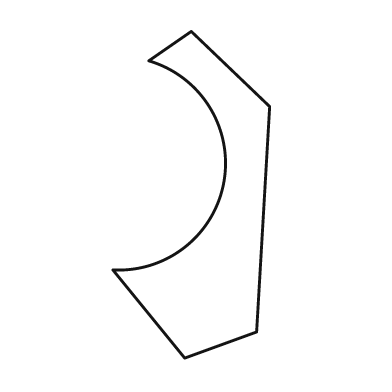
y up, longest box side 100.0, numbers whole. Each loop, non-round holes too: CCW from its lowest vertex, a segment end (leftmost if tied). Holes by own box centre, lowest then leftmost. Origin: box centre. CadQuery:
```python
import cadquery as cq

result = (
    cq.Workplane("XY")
    .moveTo(-2.0, -50.0)
    .lineTo(20.0, -42.0)
    .lineTo(24.0, 27.0)
    .lineTo(0.0, 50.0)
    .lineTo(-13.0, 41.0)
    .threePointArc((10.0, 4.0), (-24.0, -23.0))
    .close()
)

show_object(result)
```